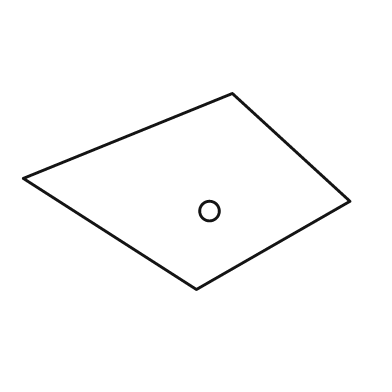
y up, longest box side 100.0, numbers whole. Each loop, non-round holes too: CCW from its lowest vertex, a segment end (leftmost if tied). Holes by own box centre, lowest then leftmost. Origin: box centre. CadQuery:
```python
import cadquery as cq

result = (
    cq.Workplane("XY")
    .moveTo(3.0, -30.0)
    .lineTo(50.0, -3.0)
    .lineTo(14.0, 30.0)
    .lineTo(-50.0, 4.0)
    .close()
    .moveTo(7.0, -6.0)
    .circle(3.0)
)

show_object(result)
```